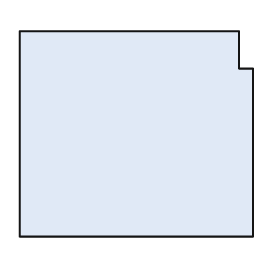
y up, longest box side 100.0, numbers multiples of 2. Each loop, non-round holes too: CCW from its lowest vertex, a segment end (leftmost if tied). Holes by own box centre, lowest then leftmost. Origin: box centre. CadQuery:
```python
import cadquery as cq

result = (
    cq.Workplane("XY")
    .moveTo(-50.0, -44.0)
    .lineTo(50.0, -44.0)
    .lineTo(50.0, 28.0)
    .lineTo(44.0, 28.0)
    .lineTo(44.0, 44.0)
    .lineTo(-50.0, 44.0)
    .close()
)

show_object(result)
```